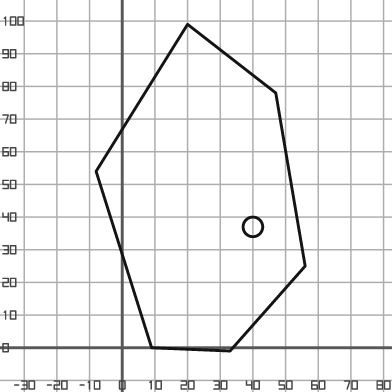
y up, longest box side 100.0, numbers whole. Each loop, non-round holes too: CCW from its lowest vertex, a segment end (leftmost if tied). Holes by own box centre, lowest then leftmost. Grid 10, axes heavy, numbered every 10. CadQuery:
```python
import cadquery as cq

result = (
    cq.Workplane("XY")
    .moveTo(33.0, -1.0)
    .lineTo(56.0, 25.0)
    .lineTo(47.0, 78.0)
    .lineTo(20.0, 99.0)
    .lineTo(-8.0, 54.0)
    .lineTo(9.0, 0.0)
    .close()
    .moveTo(40.0, 37.0)
    .circle(3.0)
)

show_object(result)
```